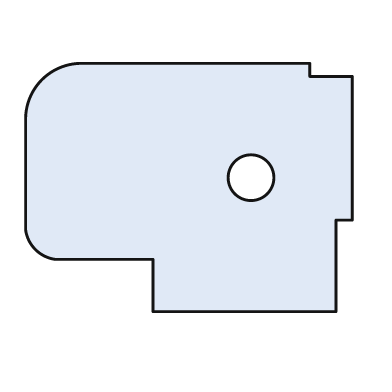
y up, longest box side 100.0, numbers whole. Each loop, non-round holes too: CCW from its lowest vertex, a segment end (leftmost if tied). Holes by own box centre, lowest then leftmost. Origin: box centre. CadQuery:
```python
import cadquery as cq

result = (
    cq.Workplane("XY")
    .moveTo(-11.0, -38.0)
    .lineTo(45.0, -38.0)
    .lineTo(45.0, -10.0)
    .lineTo(50.0, -10.0)
    .lineTo(50.0, 34.0)
    .lineTo(37.0, 34.0)
    .lineTo(37.0, 38.0)
    .lineTo(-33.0, 38.0)
    .threePointArc((-45.0, 33.0), (-50.0, 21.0))
    .lineTo(-50.0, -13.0)
    .threePointArc((-47.0, -19.0), (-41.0, -22.0))
    .lineTo(-11.0, -22.0)
    .close()
    .moveTo(19.0, 3.0)
    .circle(7.0)
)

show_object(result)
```